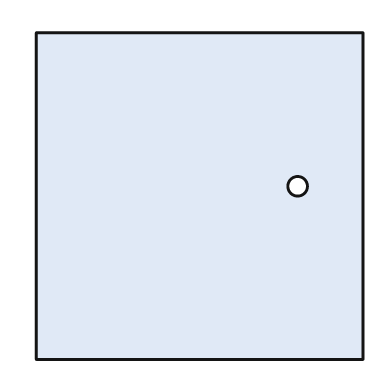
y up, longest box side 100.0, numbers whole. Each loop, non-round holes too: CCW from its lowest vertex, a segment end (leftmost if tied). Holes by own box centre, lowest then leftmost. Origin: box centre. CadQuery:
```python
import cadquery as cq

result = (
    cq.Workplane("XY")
    .moveTo(-50.0, -50.0)
    .lineTo(50.0, -50.0)
    .lineTo(50.0, 50.0)
    .lineTo(-50.0, 50.0)
    .close()
    .moveTo(30.0, 3.0)
    .circle(3.0)
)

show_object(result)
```